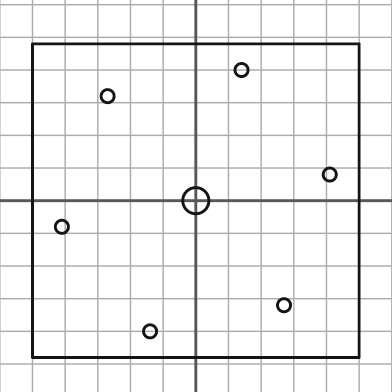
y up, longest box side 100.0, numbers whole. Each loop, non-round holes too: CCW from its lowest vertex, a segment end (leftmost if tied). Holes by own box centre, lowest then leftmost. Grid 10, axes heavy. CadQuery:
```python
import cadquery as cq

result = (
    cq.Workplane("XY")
    .moveTo(-50.0, -48.0)
    .lineTo(50.0, -48.0)
    .lineTo(50.0, 48.0)
    .lineTo(-50.0, 48.0)
    .close()
    .moveTo(-14.0, -40.0)
    .circle(2.0)
    .moveTo(27.0, -32.0)
    .circle(2.0)
    .moveTo(-41.0, -8.0)
    .circle(2.0)
    .moveTo(0.0, 0.0)
    .circle(4.0)
    .moveTo(41.0, 8.0)
    .circle(2.0)
    .moveTo(-27.0, 32.0)
    .circle(2.0)
    .moveTo(14.0, 40.0)
    .circle(2.0)
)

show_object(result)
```